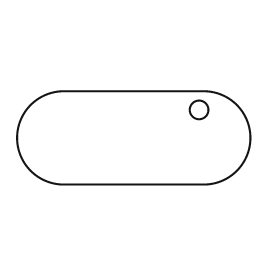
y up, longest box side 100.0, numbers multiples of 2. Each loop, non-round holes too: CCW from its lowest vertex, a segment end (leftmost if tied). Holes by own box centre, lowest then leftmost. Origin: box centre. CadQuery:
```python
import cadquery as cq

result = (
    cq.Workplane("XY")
    .moveTo(-30.0, -20.0)
    .lineTo(30.0, -20.0)
    .threePointArc((50.0, 0.0), (30.0, 20.0))
    .lineTo(-30.0, 20.0)
    .threePointArc((-50.0, 0.0), (-30.0, -20.0))
    .close()
    .moveTo(28.0, 12.0)
    .circle(4.0)
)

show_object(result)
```